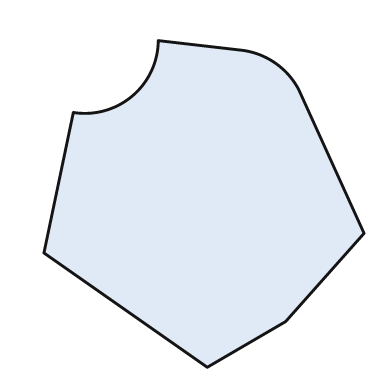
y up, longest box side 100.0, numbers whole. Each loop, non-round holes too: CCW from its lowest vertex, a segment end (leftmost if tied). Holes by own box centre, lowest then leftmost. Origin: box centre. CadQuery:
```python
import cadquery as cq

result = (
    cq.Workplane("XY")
    .moveTo(1.0, -50.0)
    .lineTo(25.0, -36.0)
    .lineTo(49.0, -9.0)
    .lineTo(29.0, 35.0)
    .threePointArc((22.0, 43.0), (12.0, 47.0))
    .lineTo(-14.0, 50.0)
    .threePointArc((-22.0, 33.0), (-40.0, 28.0))
    .lineTo(-49.0, -15.0)
    .close()
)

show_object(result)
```